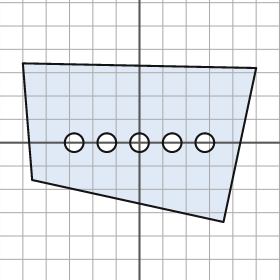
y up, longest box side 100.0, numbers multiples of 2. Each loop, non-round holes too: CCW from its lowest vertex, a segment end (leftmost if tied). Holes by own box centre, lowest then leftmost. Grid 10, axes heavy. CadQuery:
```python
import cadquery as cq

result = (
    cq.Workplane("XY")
    .moveTo(36.0, -34.0)
    .lineTo(50.0, 32.0)
    .lineTo(-50.0, 34.0)
    .lineTo(-46.0, -16.0)
    .close()
    .moveTo(-28.0, 0.0)
    .circle(4.0)
    .moveTo(-14.0, 0.0)
    .circle(4.0)
    .moveTo(0.0, 0.0)
    .circle(4.0)
    .moveTo(14.0, 0.0)
    .circle(4.0)
    .moveTo(28.0, 0.0)
    .circle(4.0)
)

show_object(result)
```